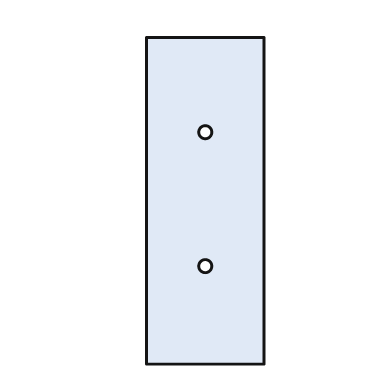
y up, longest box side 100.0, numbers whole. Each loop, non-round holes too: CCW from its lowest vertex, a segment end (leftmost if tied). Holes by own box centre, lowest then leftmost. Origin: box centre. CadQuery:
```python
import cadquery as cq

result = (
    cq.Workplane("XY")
    .moveTo(-18.0, -50.0)
    .lineTo(18.0, -50.0)
    .lineTo(18.0, 50.0)
    .lineTo(-18.0, 50.0)
    .close()
    .moveTo(0.0, -20.0)
    .circle(2.0)
    .moveTo(0.0, 21.0)
    .circle(2.0)
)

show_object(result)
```